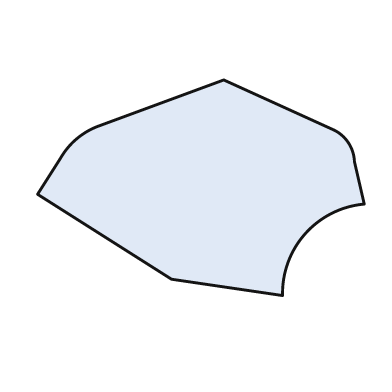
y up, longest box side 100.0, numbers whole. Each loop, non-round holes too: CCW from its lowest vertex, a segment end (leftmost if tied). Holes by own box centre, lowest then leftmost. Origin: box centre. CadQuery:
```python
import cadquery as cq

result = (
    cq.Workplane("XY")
    .moveTo(25.0, -33.0)
    .threePointArc((32.0, -14.0), (50.0, -5.0))
    .lineTo(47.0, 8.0)
    .threePointArc((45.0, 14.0), (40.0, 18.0))
    .lineTo(7.0, 33.0)
    .lineTo(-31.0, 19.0)
    .threePointArc((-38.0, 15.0), (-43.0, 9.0))
    .lineTo(-50.0, -2.0)
    .lineTo(-9.0, -28.0)
    .close()
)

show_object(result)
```